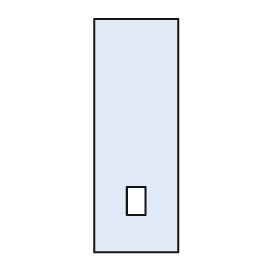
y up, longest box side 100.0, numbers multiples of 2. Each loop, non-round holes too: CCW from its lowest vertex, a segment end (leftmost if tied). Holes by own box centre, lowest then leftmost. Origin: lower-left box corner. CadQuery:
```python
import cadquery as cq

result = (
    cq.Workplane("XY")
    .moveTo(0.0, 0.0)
    .lineTo(36.0, 0.0)
    .lineTo(36.0, 100.0)
    .lineTo(0.0, 100.0)
    .close()
    .moveTo(14.0, 16.0)
    .lineTo(22.0, 16.0)
    .lineTo(22.0, 28.0)
    .lineTo(14.0, 28.0)
    .close()
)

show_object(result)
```